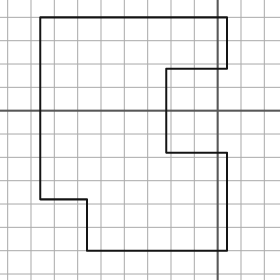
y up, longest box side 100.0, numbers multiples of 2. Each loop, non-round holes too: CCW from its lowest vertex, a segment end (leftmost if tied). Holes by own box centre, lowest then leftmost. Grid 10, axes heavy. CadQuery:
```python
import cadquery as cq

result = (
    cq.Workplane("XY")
    .moveTo(-56.0, -60.0)
    .lineTo(4.0, -60.0)
    .lineTo(4.0, -18.0)
    .lineTo(-22.0, -18.0)
    .lineTo(-22.0, 18.0)
    .lineTo(4.0, 18.0)
    .lineTo(4.0, 40.0)
    .lineTo(-76.0, 40.0)
    .lineTo(-76.0, -38.0)
    .lineTo(-56.0, -38.0)
    .close()
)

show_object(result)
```